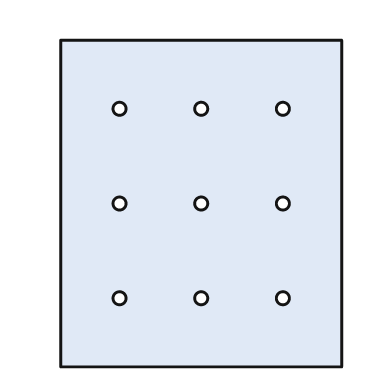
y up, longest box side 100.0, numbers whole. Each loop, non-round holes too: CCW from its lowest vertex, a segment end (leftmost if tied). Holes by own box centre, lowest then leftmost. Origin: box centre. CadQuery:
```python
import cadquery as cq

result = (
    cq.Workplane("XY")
    .moveTo(-43.0, -50.0)
    .lineTo(43.0, -50.0)
    .lineTo(43.0, 50.0)
    .lineTo(-43.0, 50.0)
    .close()
    .moveTo(-25.0, -29.0)
    .circle(2.0)
    .moveTo(0.0, -29.0)
    .circle(2.0)
    .moveTo(25.0, -29.0)
    .circle(2.0)
    .moveTo(-25.0, 0.0)
    .circle(2.0)
    .moveTo(0.0, 0.0)
    .circle(2.0)
    .moveTo(25.0, 0.0)
    .circle(2.0)
    .moveTo(-25.0, 29.0)
    .circle(2.0)
    .moveTo(0.0, 29.0)
    .circle(2.0)
    .moveTo(25.0, 29.0)
    .circle(2.0)
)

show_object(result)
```